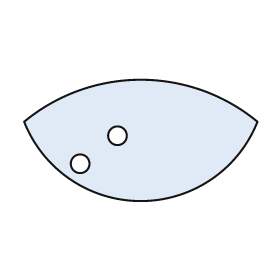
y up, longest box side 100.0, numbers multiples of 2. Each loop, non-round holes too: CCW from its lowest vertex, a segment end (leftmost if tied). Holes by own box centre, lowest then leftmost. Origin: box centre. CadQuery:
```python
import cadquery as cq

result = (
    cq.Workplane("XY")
    .moveTo(-50.0, 8.0)
    .threePointArc((0.0, -26.0), (50.0, 8.0))
    .threePointArc((0.0, 26.0), (-50.0, 8.0))
    .close()
    .moveTo(-26.0, -10.0)
    .circle(4.0)
    .moveTo(-10.0, 2.0)
    .circle(4.0)
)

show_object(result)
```